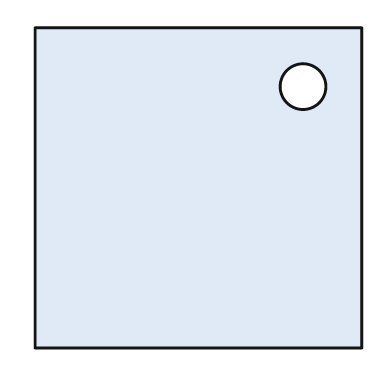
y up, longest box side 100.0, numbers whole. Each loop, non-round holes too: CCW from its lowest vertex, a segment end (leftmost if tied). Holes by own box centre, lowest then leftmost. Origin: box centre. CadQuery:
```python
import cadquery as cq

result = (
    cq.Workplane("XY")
    .moveTo(-50.0, -49.0)
    .lineTo(50.0, -49.0)
    .lineTo(50.0, 49.0)
    .lineTo(-50.0, 49.0)
    .close()
    .moveTo(32.0, 31.0)
    .circle(7.0)
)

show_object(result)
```